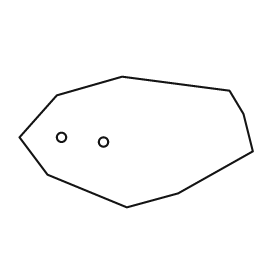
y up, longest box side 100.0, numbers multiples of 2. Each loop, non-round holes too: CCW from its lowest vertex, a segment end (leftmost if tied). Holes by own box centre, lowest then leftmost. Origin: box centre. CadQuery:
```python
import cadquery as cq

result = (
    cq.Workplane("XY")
    .moveTo(-4.0, -28.0)
    .lineTo(18.0, -22.0)
    .lineTo(50.0, -4.0)
    .lineTo(46.0, 12.0)
    .lineTo(40.0, 22.0)
    .lineTo(-6.0, 28.0)
    .lineTo(-34.0, 20.0)
    .lineTo(-50.0, 2.0)
    .lineTo(-38.0, -14.0)
    .close()
    .moveTo(-14.0, 0.0)
    .circle(2.0)
    .moveTo(-32.0, 2.0)
    .circle(2.0)
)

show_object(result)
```